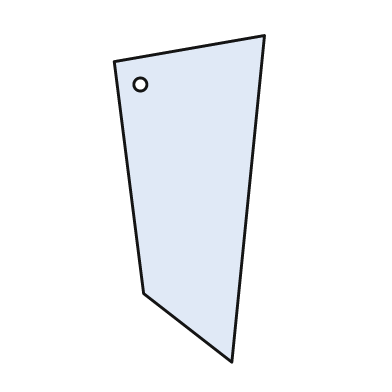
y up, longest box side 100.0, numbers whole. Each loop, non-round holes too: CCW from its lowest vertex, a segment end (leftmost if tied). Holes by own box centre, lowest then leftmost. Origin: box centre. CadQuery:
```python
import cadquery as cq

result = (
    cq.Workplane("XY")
    .moveTo(13.0, -50.0)
    .lineTo(23.0, 50.0)
    .lineTo(-23.0, 42.0)
    .lineTo(-14.0, -29.0)
    .close()
    .moveTo(-15.0, 35.0)
    .circle(2.0)
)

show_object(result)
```